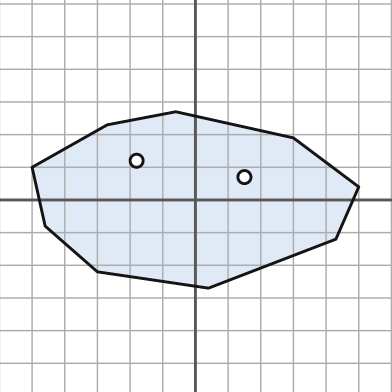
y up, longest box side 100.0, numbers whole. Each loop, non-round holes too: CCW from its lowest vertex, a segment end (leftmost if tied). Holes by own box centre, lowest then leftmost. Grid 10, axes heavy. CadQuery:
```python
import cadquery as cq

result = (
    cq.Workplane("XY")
    .moveTo(4.0, -27.0)
    .lineTo(43.0, -12.0)
    .lineTo(50.0, 4.0)
    .lineTo(30.0, 19.0)
    .lineTo(-6.0, 27.0)
    .lineTo(-27.0, 23.0)
    .lineTo(-50.0, 10.0)
    .lineTo(-46.0, -8.0)
    .lineTo(-30.0, -22.0)
    .close()
    .moveTo(15.0, 7.0)
    .circle(2.0)
    .moveTo(-18.0, 12.0)
    .circle(2.0)
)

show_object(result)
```